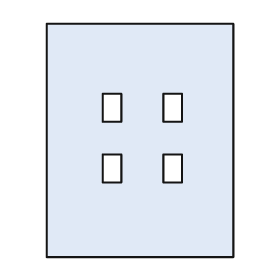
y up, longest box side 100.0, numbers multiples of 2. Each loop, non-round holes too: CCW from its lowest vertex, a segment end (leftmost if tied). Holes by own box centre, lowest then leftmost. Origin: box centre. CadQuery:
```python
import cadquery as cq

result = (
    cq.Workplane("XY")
    .moveTo(-40.0, -50.0)
    .lineTo(40.0, -50.0)
    .lineTo(40.0, 50.0)
    .lineTo(-40.0, 50.0)
    .close()
    .moveTo(-16.0, -18.0)
    .lineTo(-8.0, -18.0)
    .lineTo(-8.0, -6.0)
    .lineTo(-16.0, -6.0)
    .close()
    .moveTo(10.0, -18.0)
    .lineTo(18.0, -18.0)
    .lineTo(18.0, -6.0)
    .lineTo(10.0, -6.0)
    .close()
    .moveTo(-16.0, 8.0)
    .lineTo(-8.0, 8.0)
    .lineTo(-8.0, 20.0)
    .lineTo(-16.0, 20.0)
    .close()
    .moveTo(10.0, 8.0)
    .lineTo(18.0, 8.0)
    .lineTo(18.0, 20.0)
    .lineTo(10.0, 20.0)
    .close()
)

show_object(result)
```